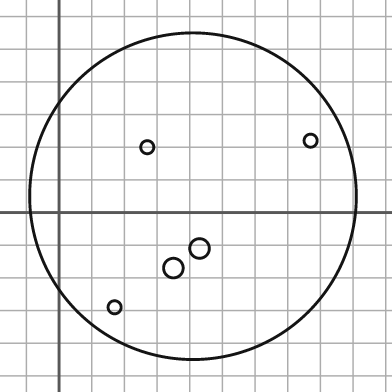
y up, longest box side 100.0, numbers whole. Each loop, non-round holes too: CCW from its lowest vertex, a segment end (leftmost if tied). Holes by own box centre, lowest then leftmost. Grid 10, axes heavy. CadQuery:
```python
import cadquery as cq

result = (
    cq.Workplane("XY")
    .moveTo(41.0, 5.0)
    .circle(50.0)
    .moveTo(17.0, -29.0)
    .circle(2.0)
    .moveTo(35.0, -17.0)
    .circle(3.0)
    .moveTo(43.0, -11.0)
    .circle(3.0)
    .moveTo(27.0, 20.0)
    .circle(2.0)
    .moveTo(77.0, 22.0)
    .circle(2.0)
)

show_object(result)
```